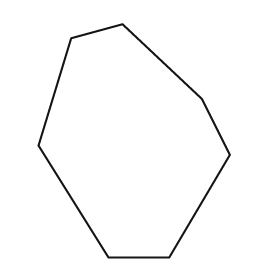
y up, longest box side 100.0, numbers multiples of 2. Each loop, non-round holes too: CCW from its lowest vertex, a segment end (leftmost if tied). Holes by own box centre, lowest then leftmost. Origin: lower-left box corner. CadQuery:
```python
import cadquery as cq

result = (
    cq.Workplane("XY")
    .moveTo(30.0, 0.0)
    .lineTo(56.0, 0.0)
    .lineTo(82.0, 44.0)
    .lineTo(70.0, 68.0)
    .lineTo(36.0, 100.0)
    .lineTo(14.0, 94.0)
    .lineTo(0.0, 48.0)
    .close()
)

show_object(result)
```